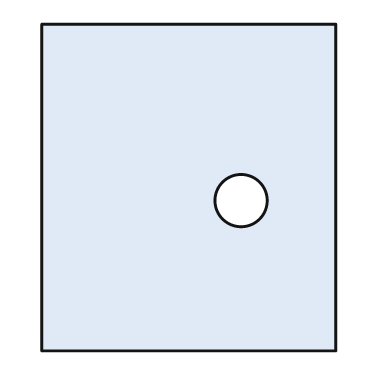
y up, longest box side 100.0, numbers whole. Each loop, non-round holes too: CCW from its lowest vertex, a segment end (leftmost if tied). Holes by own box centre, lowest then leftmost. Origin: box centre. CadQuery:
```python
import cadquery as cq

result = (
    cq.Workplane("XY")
    .moveTo(-45.0, -50.0)
    .lineTo(45.0, -50.0)
    .lineTo(45.0, 50.0)
    .lineTo(-45.0, 50.0)
    .close()
    .moveTo(16.0, -4.0)
    .circle(8.0)
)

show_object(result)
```